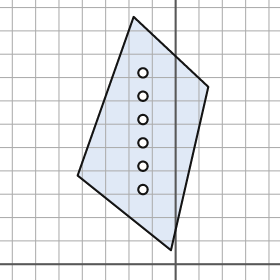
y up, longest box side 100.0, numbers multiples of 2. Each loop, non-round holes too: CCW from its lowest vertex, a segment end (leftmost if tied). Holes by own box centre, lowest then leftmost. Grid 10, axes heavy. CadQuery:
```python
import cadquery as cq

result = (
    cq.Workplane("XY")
    .moveTo(-2.0, 6.0)
    .lineTo(14.0, 76.0)
    .lineTo(-18.0, 106.0)
    .lineTo(-42.0, 38.0)
    .close()
    .moveTo(-14.0, 32.0)
    .circle(2.0)
    .moveTo(-14.0, 42.0)
    .circle(2.0)
    .moveTo(-14.0, 52.0)
    .circle(2.0)
    .moveTo(-14.0, 62.0)
    .circle(2.0)
    .moveTo(-14.0, 72.0)
    .circle(2.0)
    .moveTo(-14.0, 82.0)
    .circle(2.0)
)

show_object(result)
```